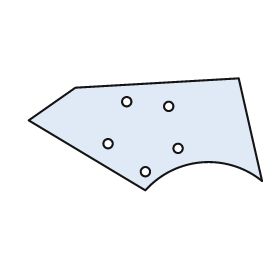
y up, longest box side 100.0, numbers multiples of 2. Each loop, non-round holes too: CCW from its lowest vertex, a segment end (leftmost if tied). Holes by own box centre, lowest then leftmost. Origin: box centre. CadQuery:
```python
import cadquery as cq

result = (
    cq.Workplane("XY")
    .moveTo(0.0, -24.0)
    .threePointArc((24.0, -12.0), (50.0, -20.0))
    .lineTo(40.0, 24.0)
    .lineTo(-30.0, 20.0)
    .lineTo(-50.0, 6.0)
    .close()
    .moveTo(0.0, -16.0)
    .circle(2.0)
    .moveTo(14.0, -6.0)
    .circle(2.0)
    .moveTo(-16.0, -4.0)
    .circle(2.0)
    .moveTo(10.0, 12.0)
    .circle(2.0)
    .moveTo(-8.0, 14.0)
    .circle(2.0)
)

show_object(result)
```